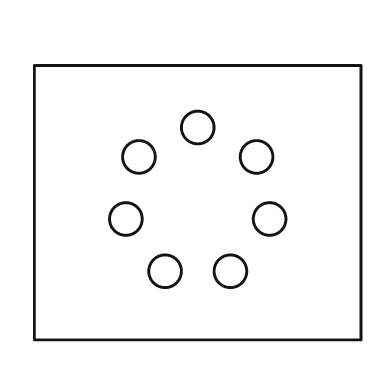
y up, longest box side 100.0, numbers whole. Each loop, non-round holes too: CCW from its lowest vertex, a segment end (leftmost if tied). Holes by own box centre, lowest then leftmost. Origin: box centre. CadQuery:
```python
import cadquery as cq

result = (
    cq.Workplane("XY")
    .moveTo(-50.0, -42.0)
    .lineTo(50.0, -42.0)
    .lineTo(50.0, 42.0)
    .lineTo(-50.0, 42.0)
    .close()
    .moveTo(-10.0, -21.0)
    .circle(5.0)
    .moveTo(10.0, -21.0)
    .circle(5.0)
    .moveTo(-22.0, -5.0)
    .circle(5.0)
    .moveTo(22.0, -5.0)
    .circle(5.0)
    .moveTo(-18.0, 14.0)
    .circle(5.0)
    .moveTo(18.0, 14.0)
    .circle(5.0)
    .moveTo(0.0, 23.0)
    .circle(5.0)
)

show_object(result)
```